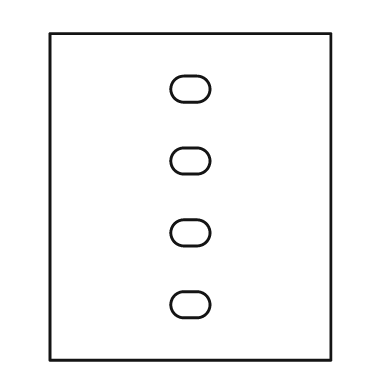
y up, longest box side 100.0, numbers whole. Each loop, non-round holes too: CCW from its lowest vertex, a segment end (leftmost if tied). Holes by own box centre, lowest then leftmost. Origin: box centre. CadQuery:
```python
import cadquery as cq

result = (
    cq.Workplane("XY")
    .moveTo(-43.0, -50.0)
    .lineTo(43.0, -50.0)
    .lineTo(43.0, 50.0)
    .lineTo(-43.0, 50.0)
    .close()
    .moveTo(-2.0, -37.0)
    .lineTo(2.0, -37.0)
    .threePointArc((6.0, -33.0), (2.0, -29.0))
    .lineTo(-2.0, -29.0)
    .threePointArc((-6.0, -33.0), (-2.0, -37.0))
    .close()
    .moveTo(-2.0, -15.0)
    .lineTo(2.0, -15.0)
    .threePointArc((6.0, -11.0), (2.0, -7.0))
    .lineTo(-2.0, -7.0)
    .threePointArc((-6.0, -11.0), (-2.0, -15.0))
    .close()
    .moveTo(-2.0, 7.0)
    .lineTo(2.0, 7.0)
    .threePointArc((6.0, 11.0), (2.0, 15.0))
    .lineTo(-2.0, 15.0)
    .threePointArc((-6.0, 11.0), (-2.0, 7.0))
    .close()
    .moveTo(-2.0, 29.0)
    .lineTo(2.0, 29.0)
    .threePointArc((6.0, 33.0), (2.0, 37.0))
    .lineTo(-2.0, 37.0)
    .threePointArc((-6.0, 33.0), (-2.0, 29.0))
    .close()
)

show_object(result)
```